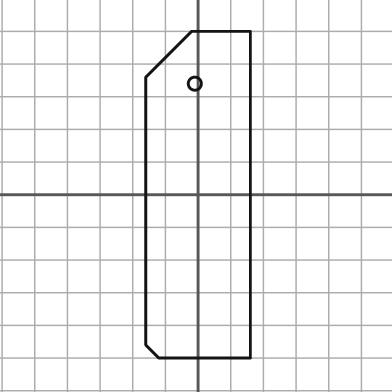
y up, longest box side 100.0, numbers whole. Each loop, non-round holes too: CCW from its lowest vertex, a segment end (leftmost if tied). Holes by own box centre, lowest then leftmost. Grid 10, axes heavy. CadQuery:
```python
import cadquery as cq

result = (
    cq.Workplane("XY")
    .moveTo(-12.0, -50.0)
    .lineTo(16.0, -50.0)
    .lineTo(16.0, 50.0)
    .lineTo(-2.0, 50.0)
    .lineTo(-16.0, 36.0)
    .lineTo(-16.0, -46.0)
    .close()
    .moveTo(-1.0, 34.0)
    .circle(2.0)
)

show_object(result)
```